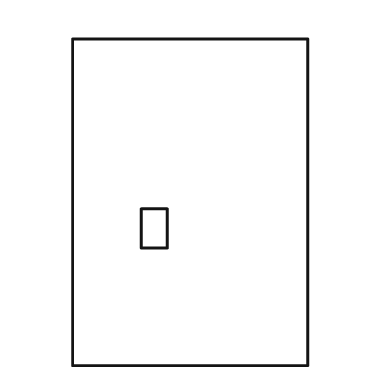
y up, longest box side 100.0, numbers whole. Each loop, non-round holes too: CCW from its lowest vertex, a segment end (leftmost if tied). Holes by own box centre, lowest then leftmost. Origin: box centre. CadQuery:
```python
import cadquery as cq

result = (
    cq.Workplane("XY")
    .moveTo(-36.0, -50.0)
    .lineTo(36.0, -50.0)
    .lineTo(36.0, 50.0)
    .lineTo(-36.0, 50.0)
    .close()
    .moveTo(-15.0, -14.0)
    .lineTo(-7.0, -14.0)
    .lineTo(-7.0, -2.0)
    .lineTo(-15.0, -2.0)
    .close()
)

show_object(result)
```